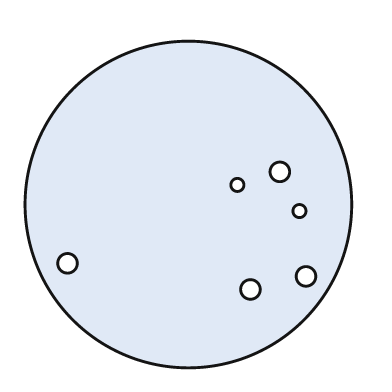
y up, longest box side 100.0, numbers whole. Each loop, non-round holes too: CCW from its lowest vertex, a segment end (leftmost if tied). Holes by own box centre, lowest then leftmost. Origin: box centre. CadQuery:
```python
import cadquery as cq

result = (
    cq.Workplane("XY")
    .moveTo(0.0, 0.0)
    .circle(50.0)
    .moveTo(19.0, -26.0)
    .circle(3.0)
    .moveTo(36.0, -22.0)
    .circle(3.0)
    .moveTo(-37.0, -18.0)
    .circle(3.0)
    .moveTo(34.0, -2.0)
    .circle(2.0)
    .moveTo(15.0, 6.0)
    .circle(2.0)
    .moveTo(28.0, 10.0)
    .circle(3.0)
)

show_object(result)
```